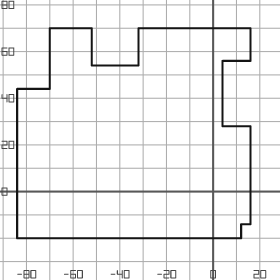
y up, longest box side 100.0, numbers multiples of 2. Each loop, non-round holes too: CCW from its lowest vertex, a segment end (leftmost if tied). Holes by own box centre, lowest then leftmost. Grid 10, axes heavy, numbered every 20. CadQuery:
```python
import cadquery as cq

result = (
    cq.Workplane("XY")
    .moveTo(-84.0, -20.0)
    .lineTo(12.0, -20.0)
    .lineTo(12.0, -14.0)
    .lineTo(16.0, -14.0)
    .lineTo(16.0, 28.0)
    .lineTo(4.0, 28.0)
    .lineTo(4.0, 56.0)
    .lineTo(16.0, 56.0)
    .lineTo(16.0, 70.0)
    .lineTo(-32.0, 70.0)
    .lineTo(-32.0, 54.0)
    .lineTo(-52.0, 54.0)
    .lineTo(-52.0, 70.0)
    .lineTo(-70.0, 70.0)
    .lineTo(-70.0, 44.0)
    .lineTo(-84.0, 44.0)
    .close()
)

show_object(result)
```